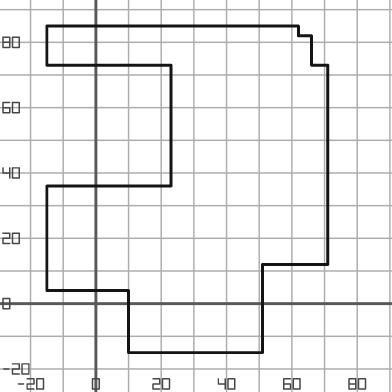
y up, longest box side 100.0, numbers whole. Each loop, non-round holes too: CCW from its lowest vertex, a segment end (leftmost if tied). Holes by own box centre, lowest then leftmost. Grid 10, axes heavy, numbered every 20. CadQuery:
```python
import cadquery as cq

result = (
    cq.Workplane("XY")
    .moveTo(10.0, -15.0)
    .lineTo(51.0, -15.0)
    .lineTo(51.0, 12.0)
    .lineTo(71.0, 12.0)
    .lineTo(71.0, 73.0)
    .lineTo(66.0, 73.0)
    .lineTo(66.0, 82.0)
    .lineTo(62.0, 82.0)
    .lineTo(62.0, 85.0)
    .lineTo(-15.0, 85.0)
    .lineTo(-15.0, 73.0)
    .lineTo(23.0, 73.0)
    .lineTo(23.0, 36.0)
    .lineTo(-15.0, 36.0)
    .lineTo(-15.0, 4.0)
    .lineTo(10.0, 4.0)
    .close()
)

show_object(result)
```